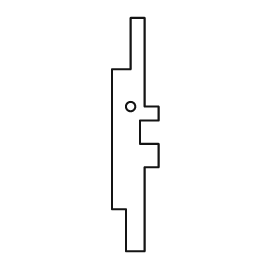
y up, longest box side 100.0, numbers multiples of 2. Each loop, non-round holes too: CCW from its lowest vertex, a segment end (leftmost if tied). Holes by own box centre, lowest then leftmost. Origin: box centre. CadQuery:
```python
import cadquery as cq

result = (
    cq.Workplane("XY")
    .moveTo(-4.0, -50.0)
    .lineTo(4.0, -50.0)
    .lineTo(4.0, -14.0)
    .lineTo(10.0, -14.0)
    .lineTo(10.0, -4.0)
    .lineTo(2.0, -4.0)
    .lineTo(2.0, 6.0)
    .lineTo(10.0, 6.0)
    .lineTo(10.0, 12.0)
    .lineTo(4.0, 12.0)
    .lineTo(4.0, 50.0)
    .lineTo(-2.0, 50.0)
    .lineTo(-2.0, 28.0)
    .lineTo(-10.0, 28.0)
    .lineTo(-10.0, -32.0)
    .lineTo(-4.0, -32.0)
    .close()
    .moveTo(-2.0, 12.0)
    .circle(2.0)
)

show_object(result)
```